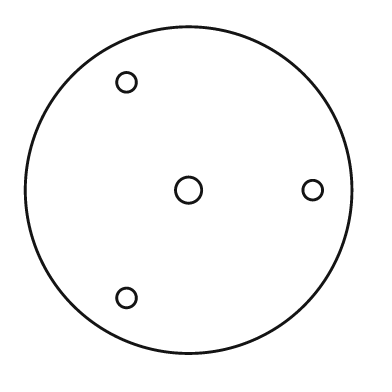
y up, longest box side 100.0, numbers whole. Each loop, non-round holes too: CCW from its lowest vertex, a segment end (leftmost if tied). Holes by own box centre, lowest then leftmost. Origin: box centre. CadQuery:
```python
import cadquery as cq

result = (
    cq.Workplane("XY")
    .moveTo(0.0, 0.0)
    .circle(50.0)
    .moveTo(-19.0, -33.0)
    .circle(3.0)
    .moveTo(0.0, 0.0)
    .circle(4.0)
    .moveTo(38.0, 0.0)
    .circle(3.0)
    .moveTo(-19.0, 33.0)
    .circle(3.0)
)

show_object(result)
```